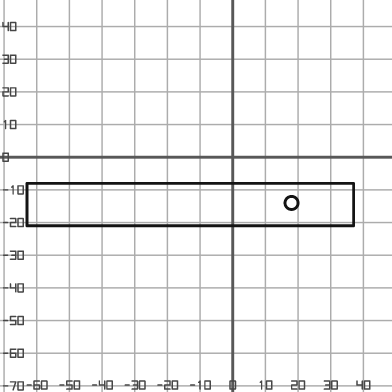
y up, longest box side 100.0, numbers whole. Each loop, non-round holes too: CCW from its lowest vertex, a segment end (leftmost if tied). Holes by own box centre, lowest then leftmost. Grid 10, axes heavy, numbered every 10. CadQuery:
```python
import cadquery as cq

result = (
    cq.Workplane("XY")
    .moveTo(-63.0, -21.0)
    .lineTo(37.0, -21.0)
    .lineTo(37.0, -8.0)
    .lineTo(-63.0, -8.0)
    .close()
    .moveTo(18.0, -14.0)
    .circle(2.0)
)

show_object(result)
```